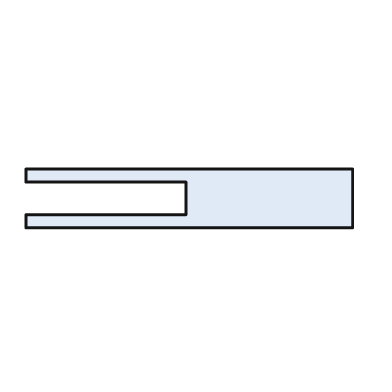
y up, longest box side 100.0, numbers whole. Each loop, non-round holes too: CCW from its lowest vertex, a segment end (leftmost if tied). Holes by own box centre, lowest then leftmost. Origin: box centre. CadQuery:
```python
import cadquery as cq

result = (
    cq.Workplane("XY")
    .moveTo(-50.0, -9.0)
    .lineTo(50.0, -9.0)
    .lineTo(50.0, 9.0)
    .lineTo(-50.0, 9.0)
    .lineTo(-50.0, 5.0)
    .lineTo(-1.0, 5.0)
    .lineTo(-1.0, -5.0)
    .lineTo(-50.0, -5.0)
    .close()
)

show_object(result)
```